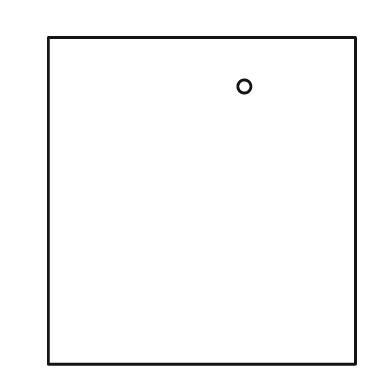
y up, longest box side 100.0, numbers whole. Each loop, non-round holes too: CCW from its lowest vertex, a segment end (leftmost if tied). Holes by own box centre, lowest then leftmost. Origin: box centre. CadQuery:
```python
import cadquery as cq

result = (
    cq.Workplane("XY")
    .moveTo(-47.0, -50.0)
    .lineTo(47.0, -50.0)
    .lineTo(47.0, 50.0)
    .lineTo(-47.0, 50.0)
    .close()
    .moveTo(13.0, 35.0)
    .circle(2.0)
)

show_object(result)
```